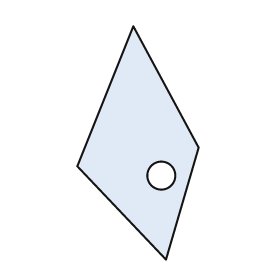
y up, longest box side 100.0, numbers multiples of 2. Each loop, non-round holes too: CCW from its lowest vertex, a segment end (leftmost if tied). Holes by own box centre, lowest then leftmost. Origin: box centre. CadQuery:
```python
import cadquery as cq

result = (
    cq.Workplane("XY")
    .moveTo(12.0, -50.0)
    .lineTo(26.0, -2.0)
    .lineTo(-2.0, 50.0)
    .lineTo(-26.0, -10.0)
    .close()
    .moveTo(10.0, -14.0)
    .circle(6.0)
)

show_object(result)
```